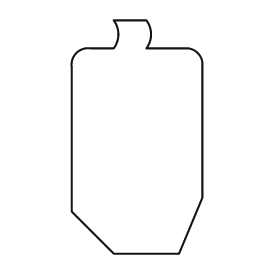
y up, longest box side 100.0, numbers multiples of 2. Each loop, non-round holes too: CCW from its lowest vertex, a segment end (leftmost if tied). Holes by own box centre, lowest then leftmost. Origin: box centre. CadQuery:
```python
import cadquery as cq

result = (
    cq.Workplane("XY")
    .moveTo(-10.0, -50.0)
    .lineTo(18.0, -50.0)
    .lineTo(28.0, -26.0)
    .lineTo(28.0, 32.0)
    .threePointArc((26.0, 36.0), (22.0, 38.0))
    .lineTo(4.0, 38.0)
    .threePointArc((6.0, 44.0), (4.0, 50.0))
    .lineTo(-10.0, 50.0)
    .threePointArc((-8.0, 44.0), (-10.0, 38.0))
    .lineTo(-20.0, 38.0)
    .threePointArc((-26.0, 36.0), (-28.0, 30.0))
    .lineTo(-28.0, -32.0)
    .close()
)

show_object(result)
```